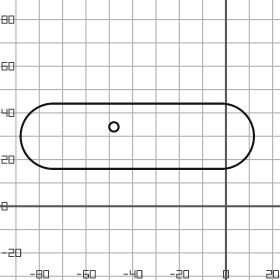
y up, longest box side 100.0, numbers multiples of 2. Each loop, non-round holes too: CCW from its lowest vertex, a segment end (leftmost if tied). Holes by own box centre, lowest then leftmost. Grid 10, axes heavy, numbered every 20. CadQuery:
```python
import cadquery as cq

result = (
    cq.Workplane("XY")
    .moveTo(-74.0, 16.0)
    .lineTo(-2.0, 16.0)
    .threePointArc((12.0, 30.0), (-2.0, 44.0))
    .lineTo(-74.0, 44.0)
    .threePointArc((-88.0, 30.0), (-74.0, 16.0))
    .close()
    .moveTo(-48.0, 34.0)
    .circle(2.0)
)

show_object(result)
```